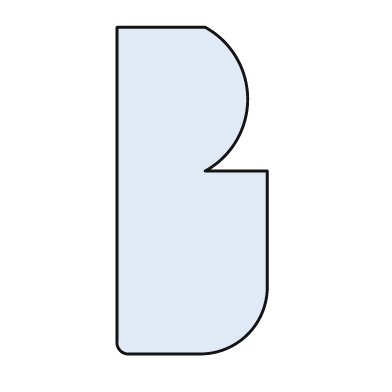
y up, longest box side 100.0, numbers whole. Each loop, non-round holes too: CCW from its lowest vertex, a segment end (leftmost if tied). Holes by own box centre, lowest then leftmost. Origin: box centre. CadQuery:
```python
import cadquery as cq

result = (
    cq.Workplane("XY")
    .moveTo(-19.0, -50.0)
    .lineTo(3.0, -50.0)
    .threePointArc((17.0, -44.0), (23.0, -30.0))
    .lineTo(23.0, 6.0)
    .lineTo(4.0, 6.0)
    .threePointArc((17.0, 28.0), (4.0, 50.0))
    .lineTo(-23.0, 50.0)
    .lineTo(-23.0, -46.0)
    .threePointArc((-22.0, -49.0), (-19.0, -50.0))
    .close()
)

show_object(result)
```